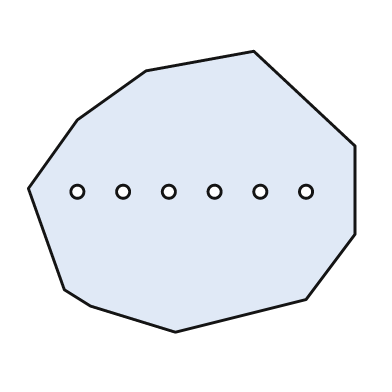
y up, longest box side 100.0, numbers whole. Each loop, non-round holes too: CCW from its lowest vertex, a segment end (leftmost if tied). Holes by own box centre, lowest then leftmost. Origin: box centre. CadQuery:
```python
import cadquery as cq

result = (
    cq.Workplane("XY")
    .moveTo(-5.0, -43.0)
    .lineTo(35.0, -33.0)
    .lineTo(50.0, -13.0)
    .lineTo(50.0, 14.0)
    .lineTo(19.0, 43.0)
    .lineTo(-14.0, 37.0)
    .lineTo(-35.0, 22.0)
    .lineTo(-50.0, 1.0)
    .lineTo(-39.0, -30.0)
    .lineTo(-31.0, -35.0)
    .close()
    .moveTo(-35.0, 0.0)
    .circle(2.0)
    .moveTo(-21.0, 0.0)
    .circle(2.0)
    .moveTo(-7.0, 0.0)
    .circle(2.0)
    .moveTo(7.0, 0.0)
    .circle(2.0)
    .moveTo(21.0, 0.0)
    .circle(2.0)
    .moveTo(35.0, 0.0)
    .circle(2.0)
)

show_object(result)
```